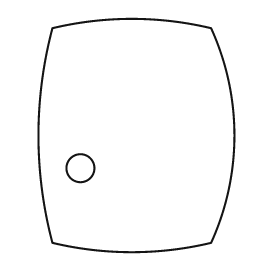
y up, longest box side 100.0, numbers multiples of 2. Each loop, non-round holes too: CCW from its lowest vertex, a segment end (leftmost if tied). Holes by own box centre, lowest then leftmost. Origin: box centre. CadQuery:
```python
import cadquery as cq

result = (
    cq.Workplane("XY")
    .moveTo(-36.0, -46.0)
    .threePointArc((-2.0, -50.0), (32.0, -46.0))
    .threePointArc((42.0, 0.0), (32.0, 46.0))
    .threePointArc((-2.0, 50.0), (-36.0, 46.0))
    .threePointArc((-42.0, 0.0), (-36.0, -46.0))
    .close()
    .moveTo(-24.0, -14.0)
    .circle(6.0)
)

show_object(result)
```